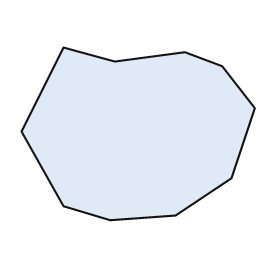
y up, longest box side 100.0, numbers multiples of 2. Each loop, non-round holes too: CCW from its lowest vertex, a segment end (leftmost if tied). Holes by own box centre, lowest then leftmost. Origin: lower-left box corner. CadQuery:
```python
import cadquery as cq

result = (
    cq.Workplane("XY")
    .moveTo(38.0, 0.0)
    .lineTo(66.0, 2.0)
    .lineTo(90.0, 18.0)
    .lineTo(100.0, 48.0)
    .lineTo(86.0, 66.0)
    .lineTo(70.0, 72.0)
    .lineTo(40.0, 68.0)
    .lineTo(18.0, 74.0)
    .lineTo(0.0, 38.0)
    .lineTo(18.0, 6.0)
    .close()
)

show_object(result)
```